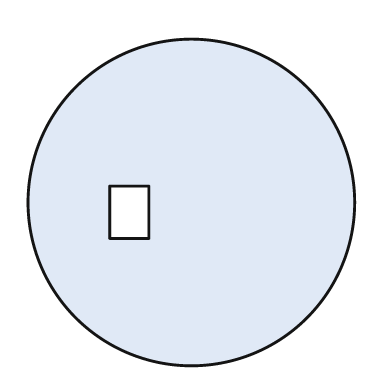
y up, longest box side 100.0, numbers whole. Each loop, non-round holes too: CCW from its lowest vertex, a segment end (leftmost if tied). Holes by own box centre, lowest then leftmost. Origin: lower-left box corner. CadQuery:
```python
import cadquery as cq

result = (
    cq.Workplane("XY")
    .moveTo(50.0, 50.0)
    .circle(50.0)
    .moveTo(25.0, 39.0)
    .lineTo(37.0, 39.0)
    .lineTo(37.0, 55.0)
    .lineTo(25.0, 55.0)
    .close()
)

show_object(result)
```